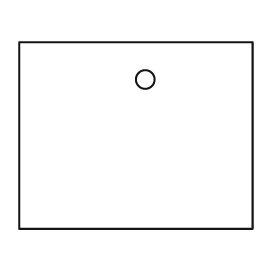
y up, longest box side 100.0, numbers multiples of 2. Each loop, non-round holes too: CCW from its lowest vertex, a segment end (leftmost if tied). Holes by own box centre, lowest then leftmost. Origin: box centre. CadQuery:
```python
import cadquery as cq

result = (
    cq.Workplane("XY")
    .moveTo(-50.0, -40.0)
    .lineTo(50.0, -40.0)
    .lineTo(50.0, 40.0)
    .lineTo(-50.0, 40.0)
    .close()
    .moveTo(4.0, 24.0)
    .circle(4.0)
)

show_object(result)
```